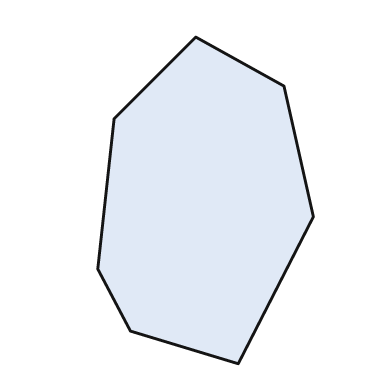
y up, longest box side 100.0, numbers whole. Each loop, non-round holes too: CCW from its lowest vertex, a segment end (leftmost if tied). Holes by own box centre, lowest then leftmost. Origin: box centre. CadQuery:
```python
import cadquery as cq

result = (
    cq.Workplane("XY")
    .moveTo(10.0, -50.0)
    .lineTo(33.0, -5.0)
    .lineTo(24.0, 35.0)
    .lineTo(-3.0, 50.0)
    .lineTo(-28.0, 25.0)
    .lineTo(-33.0, -21.0)
    .lineTo(-23.0, -40.0)
    .close()
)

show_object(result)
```